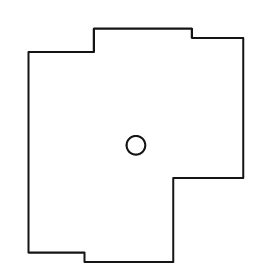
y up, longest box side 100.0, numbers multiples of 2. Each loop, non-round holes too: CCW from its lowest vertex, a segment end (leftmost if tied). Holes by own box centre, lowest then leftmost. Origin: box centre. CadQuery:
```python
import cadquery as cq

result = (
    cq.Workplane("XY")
    .moveTo(-22.0, -50.0)
    .lineTo(16.0, -50.0)
    .lineTo(16.0, -14.0)
    .lineTo(46.0, -14.0)
    .lineTo(46.0, 46.0)
    .lineTo(24.0, 46.0)
    .lineTo(24.0, 50.0)
    .lineTo(-18.0, 50.0)
    .lineTo(-18.0, 40.0)
    .lineTo(-46.0, 40.0)
    .lineTo(-46.0, -46.0)
    .lineTo(-22.0, -46.0)
    .close()
    .moveTo(0.0, 0.0)
    .circle(4.0)
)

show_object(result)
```